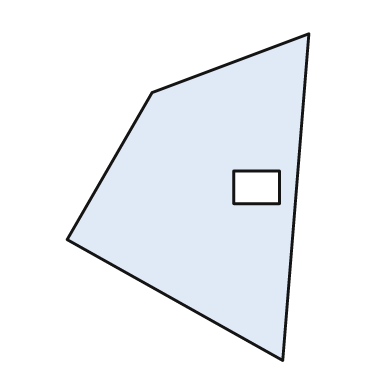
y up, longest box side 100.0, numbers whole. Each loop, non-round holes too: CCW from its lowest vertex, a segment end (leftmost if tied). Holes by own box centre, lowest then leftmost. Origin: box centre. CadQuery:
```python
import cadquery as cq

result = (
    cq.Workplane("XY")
    .moveTo(29.0, -50.0)
    .lineTo(37.0, 50.0)
    .lineTo(-11.0, 32.0)
    .lineTo(-37.0, -13.0)
    .close()
    .moveTo(14.0, -2.0)
    .lineTo(28.0, -2.0)
    .lineTo(28.0, 8.0)
    .lineTo(14.0, 8.0)
    .close()
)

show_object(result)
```